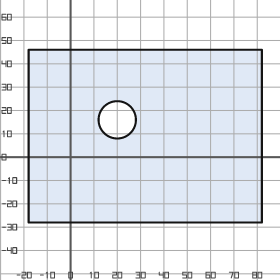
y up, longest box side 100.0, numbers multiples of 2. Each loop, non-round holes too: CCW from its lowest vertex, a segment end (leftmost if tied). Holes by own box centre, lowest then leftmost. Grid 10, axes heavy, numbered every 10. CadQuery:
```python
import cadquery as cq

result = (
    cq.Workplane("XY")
    .moveTo(-18.0, -28.0)
    .lineTo(82.0, -28.0)
    .lineTo(82.0, 46.0)
    .lineTo(-18.0, 46.0)
    .close()
    .moveTo(20.0, 16.0)
    .circle(8.0)
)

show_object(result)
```